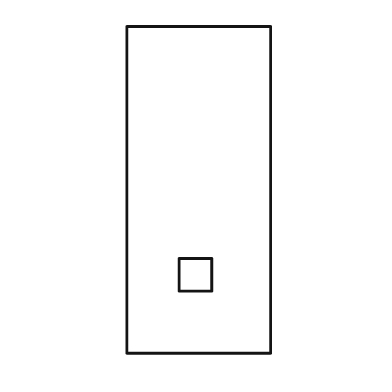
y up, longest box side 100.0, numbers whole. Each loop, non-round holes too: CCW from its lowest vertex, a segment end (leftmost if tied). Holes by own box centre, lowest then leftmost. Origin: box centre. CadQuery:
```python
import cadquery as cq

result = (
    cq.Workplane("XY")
    .moveTo(-22.0, -50.0)
    .lineTo(22.0, -50.0)
    .lineTo(22.0, 50.0)
    .lineTo(-22.0, 50.0)
    .close()
    .moveTo(-6.0, -31.0)
    .lineTo(4.0, -31.0)
    .lineTo(4.0, -21.0)
    .lineTo(-6.0, -21.0)
    .close()
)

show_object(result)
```